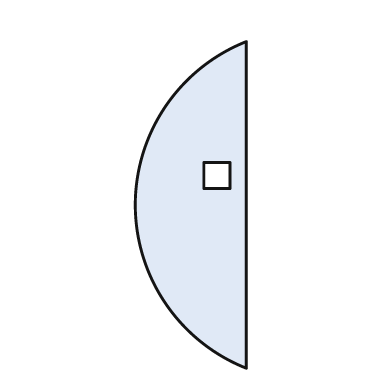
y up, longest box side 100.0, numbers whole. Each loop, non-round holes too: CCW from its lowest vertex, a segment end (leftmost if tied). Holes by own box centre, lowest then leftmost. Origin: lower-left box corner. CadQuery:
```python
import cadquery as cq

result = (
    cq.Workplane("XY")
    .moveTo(34.0, 0.0)
    .lineTo(34.0, 100.0)
    .threePointArc((0.0, 50.0), (34.0, 0.0))
    .close()
    .moveTo(21.0, 55.0)
    .lineTo(29.0, 55.0)
    .lineTo(29.0, 63.0)
    .lineTo(21.0, 63.0)
    .close()
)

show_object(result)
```